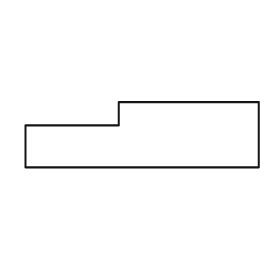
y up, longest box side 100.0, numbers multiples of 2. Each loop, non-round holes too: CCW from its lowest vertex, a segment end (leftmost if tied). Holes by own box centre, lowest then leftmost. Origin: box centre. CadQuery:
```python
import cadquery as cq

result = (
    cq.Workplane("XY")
    .moveTo(-50.0, -14.0)
    .lineTo(50.0, -14.0)
    .lineTo(50.0, 14.0)
    .lineTo(-10.0, 14.0)
    .lineTo(-10.0, 4.0)
    .lineTo(-50.0, 4.0)
    .close()
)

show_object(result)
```